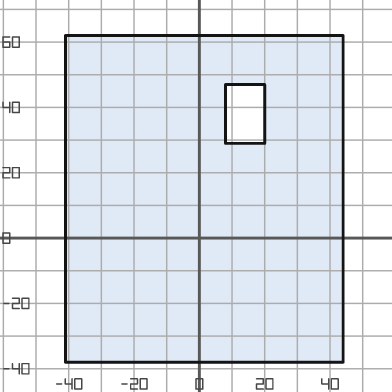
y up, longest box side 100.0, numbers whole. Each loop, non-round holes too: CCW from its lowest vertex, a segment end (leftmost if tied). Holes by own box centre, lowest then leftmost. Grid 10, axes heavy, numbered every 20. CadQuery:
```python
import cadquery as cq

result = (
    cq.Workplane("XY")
    .moveTo(-41.0, -38.0)
    .lineTo(44.0, -38.0)
    .lineTo(44.0, 62.0)
    .lineTo(-41.0, 62.0)
    .close()
    .moveTo(8.0, 29.0)
    .lineTo(20.0, 29.0)
    .lineTo(20.0, 47.0)
    .lineTo(8.0, 47.0)
    .close()
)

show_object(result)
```